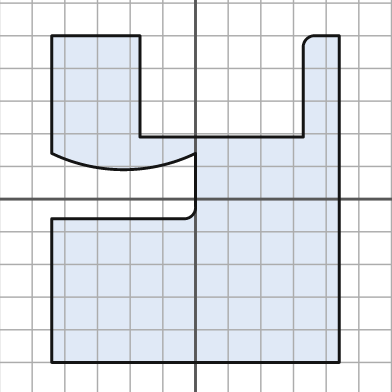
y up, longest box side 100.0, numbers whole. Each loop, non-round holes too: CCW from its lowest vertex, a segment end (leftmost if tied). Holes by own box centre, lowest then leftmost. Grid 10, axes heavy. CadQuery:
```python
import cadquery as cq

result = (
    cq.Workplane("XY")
    .moveTo(-44.0, -50.0)
    .lineTo(44.0, -50.0)
    .lineTo(44.0, 50.0)
    .lineTo(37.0, 50.0)
    .threePointArc((34.0, 49.0), (33.0, 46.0))
    .lineTo(33.0, 19.0)
    .lineTo(-17.0, 19.0)
    .lineTo(-17.0, 50.0)
    .lineTo(-44.0, 50.0)
    .lineTo(-44.0, 14.0)
    .threePointArc((-22.0, 9.0), (0.0, 14.0))
    .lineTo(0.0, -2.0)
    .threePointArc((-1.0, -5.0), (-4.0, -6.0))
    .lineTo(-44.0, -6.0)
    .close()
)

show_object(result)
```